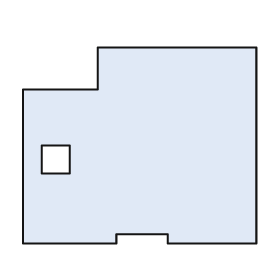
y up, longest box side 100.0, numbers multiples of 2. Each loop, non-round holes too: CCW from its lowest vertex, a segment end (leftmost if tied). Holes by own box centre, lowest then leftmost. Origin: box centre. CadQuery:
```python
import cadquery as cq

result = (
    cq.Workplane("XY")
    .moveTo(-50.0, -42.0)
    .lineTo(-10.0, -42.0)
    .lineTo(-10.0, -38.0)
    .lineTo(12.0, -38.0)
    .lineTo(12.0, -42.0)
    .lineTo(50.0, -42.0)
    .lineTo(50.0, 42.0)
    .lineTo(-18.0, 42.0)
    .lineTo(-18.0, 24.0)
    .lineTo(-50.0, 24.0)
    .close()
    .moveTo(-42.0, -12.0)
    .lineTo(-30.0, -12.0)
    .lineTo(-30.0, 0.0)
    .lineTo(-42.0, 0.0)
    .close()
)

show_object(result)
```